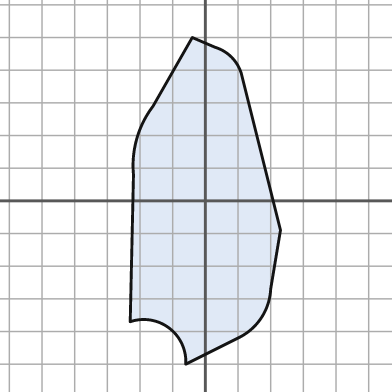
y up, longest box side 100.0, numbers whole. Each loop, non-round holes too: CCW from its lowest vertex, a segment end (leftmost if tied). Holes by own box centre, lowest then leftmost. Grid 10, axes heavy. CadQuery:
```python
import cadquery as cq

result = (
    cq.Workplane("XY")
    .moveTo(-6.0, -50.0)
    .lineTo(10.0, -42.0)
    .threePointArc((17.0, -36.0), (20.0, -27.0))
    .lineTo(23.0, -9.0)
    .lineTo(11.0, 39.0)
    .threePointArc((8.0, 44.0), (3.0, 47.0))
    .lineTo(-4.0, 50.0)
    .lineTo(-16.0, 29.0)
    .threePointArc((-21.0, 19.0), (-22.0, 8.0))
    .lineTo(-23.0, -37.0)
    .threePointArc((-11.0, -39.0), (-6.0, -50.0))
    .close()
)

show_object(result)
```